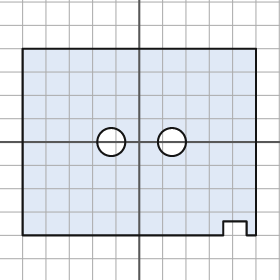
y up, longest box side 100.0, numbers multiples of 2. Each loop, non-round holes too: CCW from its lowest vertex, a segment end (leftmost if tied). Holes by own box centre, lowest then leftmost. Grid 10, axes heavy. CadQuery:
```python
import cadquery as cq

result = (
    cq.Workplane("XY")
    .moveTo(-50.0, -40.0)
    .lineTo(36.0, -40.0)
    .lineTo(36.0, -34.0)
    .lineTo(46.0, -34.0)
    .lineTo(46.0, -40.0)
    .lineTo(50.0, -40.0)
    .lineTo(50.0, 40.0)
    .lineTo(-50.0, 40.0)
    .close()
    .moveTo(-12.0, 0.0)
    .circle(6.0)
    .moveTo(14.0, 0.0)
    .circle(6.0)
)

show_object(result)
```